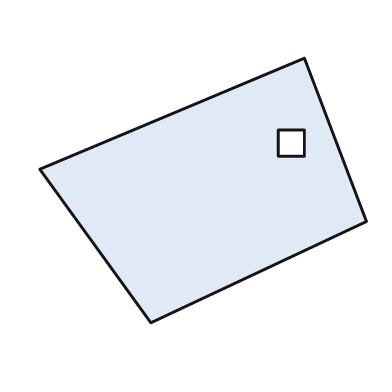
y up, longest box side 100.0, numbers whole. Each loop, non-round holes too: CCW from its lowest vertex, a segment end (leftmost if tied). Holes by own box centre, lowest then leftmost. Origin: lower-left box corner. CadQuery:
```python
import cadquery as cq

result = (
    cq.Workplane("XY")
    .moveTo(34.0, 0.0)
    .lineTo(100.0, 31.0)
    .lineTo(81.0, 81.0)
    .lineTo(0.0, 47.0)
    .close()
    .moveTo(73.0, 51.0)
    .lineTo(81.0, 51.0)
    .lineTo(81.0, 59.0)
    .lineTo(73.0, 59.0)
    .close()
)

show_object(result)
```